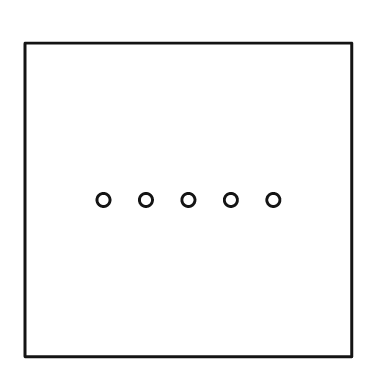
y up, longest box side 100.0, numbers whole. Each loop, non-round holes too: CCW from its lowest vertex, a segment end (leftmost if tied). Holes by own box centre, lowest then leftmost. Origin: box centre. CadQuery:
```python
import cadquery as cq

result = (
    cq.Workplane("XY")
    .moveTo(-50.0, -48.0)
    .lineTo(50.0, -48.0)
    .lineTo(50.0, 48.0)
    .lineTo(-50.0, 48.0)
    .close()
    .moveTo(-26.0, 0.0)
    .circle(2.0)
    .moveTo(-13.0, 0.0)
    .circle(2.0)
    .moveTo(0.0, 0.0)
    .circle(2.0)
    .moveTo(13.0, 0.0)
    .circle(2.0)
    .moveTo(26.0, 0.0)
    .circle(2.0)
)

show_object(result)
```